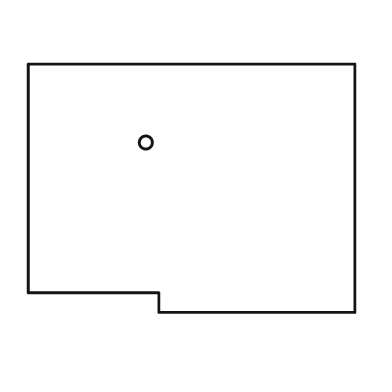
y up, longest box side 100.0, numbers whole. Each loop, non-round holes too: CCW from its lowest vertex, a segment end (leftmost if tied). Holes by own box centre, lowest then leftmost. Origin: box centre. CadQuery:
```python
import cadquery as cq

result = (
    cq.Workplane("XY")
    .moveTo(-10.0, -38.0)
    .lineTo(50.0, -38.0)
    .lineTo(50.0, 38.0)
    .lineTo(-50.0, 38.0)
    .lineTo(-50.0, -32.0)
    .lineTo(-10.0, -32.0)
    .close()
    .moveTo(-14.0, 14.0)
    .circle(2.0)
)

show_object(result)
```